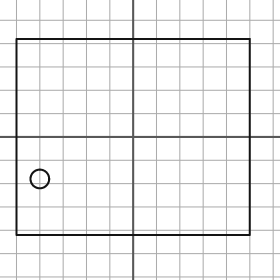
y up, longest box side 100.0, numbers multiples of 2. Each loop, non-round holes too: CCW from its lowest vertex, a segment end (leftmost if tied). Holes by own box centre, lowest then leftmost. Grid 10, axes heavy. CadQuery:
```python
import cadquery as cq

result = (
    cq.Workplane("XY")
    .moveTo(-50.0, -42.0)
    .lineTo(50.0, -42.0)
    .lineTo(50.0, 42.0)
    .lineTo(-50.0, 42.0)
    .close()
    .moveTo(-40.0, -18.0)
    .circle(4.0)
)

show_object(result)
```